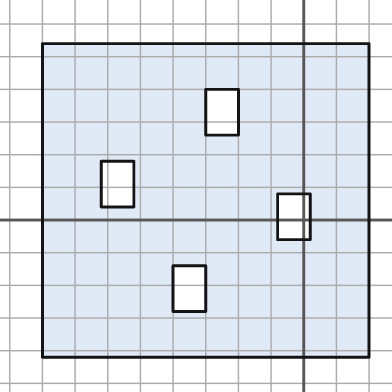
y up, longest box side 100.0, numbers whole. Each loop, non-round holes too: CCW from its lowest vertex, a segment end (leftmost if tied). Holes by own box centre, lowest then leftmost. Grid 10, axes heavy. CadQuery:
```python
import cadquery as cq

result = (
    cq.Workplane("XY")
    .moveTo(-80.0, -42.0)
    .lineTo(20.0, -42.0)
    .lineTo(20.0, 54.0)
    .lineTo(-80.0, 54.0)
    .close()
    .moveTo(-40.0, -28.0)
    .lineTo(-30.0, -28.0)
    .lineTo(-30.0, -14.0)
    .lineTo(-40.0, -14.0)
    .close()
    .moveTo(-8.0, -6.0)
    .lineTo(2.0, -6.0)
    .lineTo(2.0, 8.0)
    .lineTo(-8.0, 8.0)
    .close()
    .moveTo(-62.0, 4.0)
    .lineTo(-52.0, 4.0)
    .lineTo(-52.0, 18.0)
    .lineTo(-62.0, 18.0)
    .close()
    .moveTo(-30.0, 26.0)
    .lineTo(-20.0, 26.0)
    .lineTo(-20.0, 40.0)
    .lineTo(-30.0, 40.0)
    .close()
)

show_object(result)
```